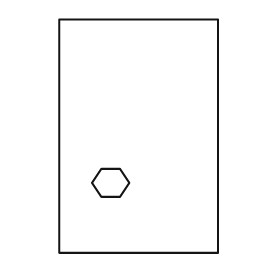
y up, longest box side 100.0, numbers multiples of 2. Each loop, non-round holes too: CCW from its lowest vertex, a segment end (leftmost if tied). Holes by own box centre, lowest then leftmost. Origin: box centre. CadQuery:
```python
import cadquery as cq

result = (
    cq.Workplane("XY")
    .moveTo(-34.0, -50.0)
    .lineTo(34.0, -50.0)
    .lineTo(34.0, 50.0)
    .lineTo(-34.0, 50.0)
    .close()
    .moveTo(-16.0, -26.0)
    .lineTo(-8.0, -26.0)
    .lineTo(-4.0, -20.0)
    .lineTo(-8.0, -14.0)
    .lineTo(-16.0, -14.0)
    .lineTo(-20.0, -20.0)
    .close()
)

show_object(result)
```